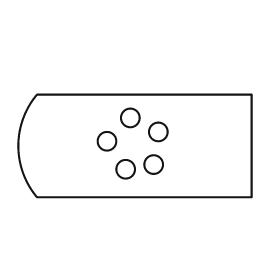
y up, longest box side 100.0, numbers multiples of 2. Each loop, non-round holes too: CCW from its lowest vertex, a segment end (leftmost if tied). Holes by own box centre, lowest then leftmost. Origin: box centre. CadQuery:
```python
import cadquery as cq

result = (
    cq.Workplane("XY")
    .moveTo(-42.0, -22.0)
    .lineTo(50.0, -22.0)
    .lineTo(50.0, 22.0)
    .lineTo(-42.0, 22.0)
    .threePointArc((-50.0, 0.0), (-42.0, -22.0))
    .close()
    .moveTo(-4.0, -10.0)
    .circle(4.0)
    .moveTo(8.0, -8.0)
    .circle(4.0)
    .moveTo(-12.0, 2.0)
    .circle(4.0)
    .moveTo(10.0, 6.0)
    .circle(4.0)
    .moveTo(-2.0, 12.0)
    .circle(4.0)
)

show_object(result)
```